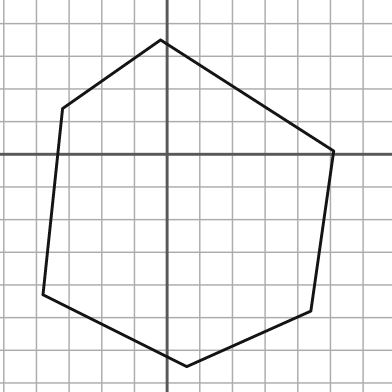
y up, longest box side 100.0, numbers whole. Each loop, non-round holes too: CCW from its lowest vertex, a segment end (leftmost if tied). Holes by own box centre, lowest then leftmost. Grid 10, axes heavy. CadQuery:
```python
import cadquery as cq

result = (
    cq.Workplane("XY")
    .moveTo(6.0, -65.0)
    .lineTo(44.0, -48.0)
    .lineTo(51.0, 1.0)
    .lineTo(-2.0, 35.0)
    .lineTo(-32.0, 14.0)
    .lineTo(-38.0, -43.0)
    .close()
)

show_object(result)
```